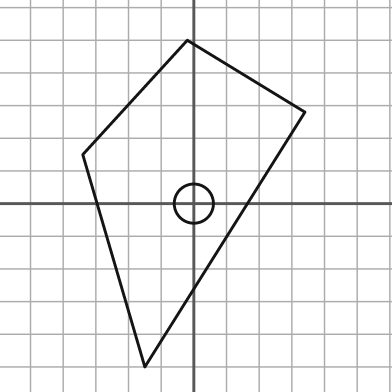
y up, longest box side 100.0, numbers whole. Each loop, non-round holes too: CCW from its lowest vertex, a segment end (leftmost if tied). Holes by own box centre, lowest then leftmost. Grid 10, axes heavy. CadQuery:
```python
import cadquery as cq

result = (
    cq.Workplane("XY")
    .moveTo(-15.0, -50.0)
    .lineTo(34.0, 28.0)
    .lineTo(-2.0, 50.0)
    .lineTo(-34.0, 15.0)
    .close()
    .moveTo(0.0, 0.0)
    .circle(6.0)
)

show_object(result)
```